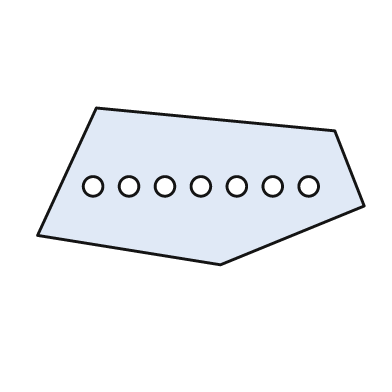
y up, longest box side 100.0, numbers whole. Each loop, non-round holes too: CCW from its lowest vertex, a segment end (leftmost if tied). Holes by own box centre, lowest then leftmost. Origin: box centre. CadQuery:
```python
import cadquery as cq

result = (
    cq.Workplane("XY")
    .moveTo(6.0, -24.0)
    .lineTo(50.0, -6.0)
    .lineTo(41.0, 17.0)
    .lineTo(-32.0, 24.0)
    .lineTo(-50.0, -15.0)
    .close()
    .moveTo(-33.0, 0.0)
    .circle(3.0)
    .moveTo(-22.0, 0.0)
    .circle(3.0)
    .moveTo(-11.0, 0.0)
    .circle(3.0)
    .moveTo(0.0, 0.0)
    .circle(3.0)
    .moveTo(11.0, 0.0)
    .circle(3.0)
    .moveTo(22.0, 0.0)
    .circle(3.0)
    .moveTo(33.0, 0.0)
    .circle(3.0)
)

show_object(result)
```